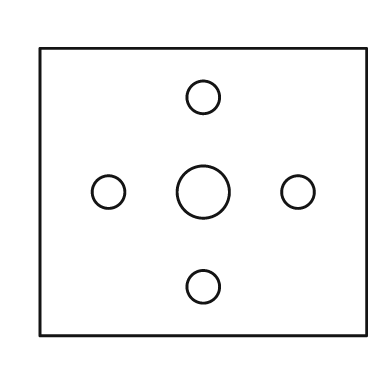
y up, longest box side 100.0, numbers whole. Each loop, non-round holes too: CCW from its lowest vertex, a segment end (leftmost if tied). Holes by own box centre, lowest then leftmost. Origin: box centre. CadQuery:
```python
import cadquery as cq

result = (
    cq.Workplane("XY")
    .moveTo(-50.0, -44.0)
    .lineTo(50.0, -44.0)
    .lineTo(50.0, 44.0)
    .lineTo(-50.0, 44.0)
    .close()
    .moveTo(0.0, -29.0)
    .circle(5.0)
    .moveTo(-29.0, 0.0)
    .circle(5.0)
    .moveTo(0.0, 0.0)
    .circle(8.0)
    .moveTo(29.0, 0.0)
    .circle(5.0)
    .moveTo(0.0, 29.0)
    .circle(5.0)
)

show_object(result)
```